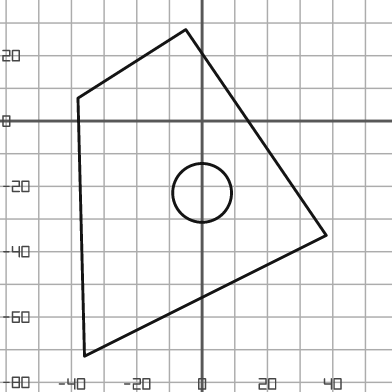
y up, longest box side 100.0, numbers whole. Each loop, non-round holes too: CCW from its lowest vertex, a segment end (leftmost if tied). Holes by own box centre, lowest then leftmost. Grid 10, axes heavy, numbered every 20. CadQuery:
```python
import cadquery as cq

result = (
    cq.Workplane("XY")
    .moveTo(-36.0, -72.0)
    .lineTo(38.0, -35.0)
    .lineTo(-5.0, 28.0)
    .lineTo(-38.0, 7.0)
    .close()
    .moveTo(0.0, -22.0)
    .circle(9.0)
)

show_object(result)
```